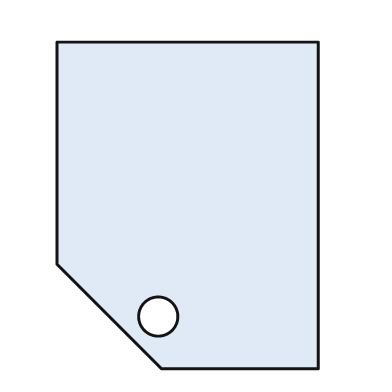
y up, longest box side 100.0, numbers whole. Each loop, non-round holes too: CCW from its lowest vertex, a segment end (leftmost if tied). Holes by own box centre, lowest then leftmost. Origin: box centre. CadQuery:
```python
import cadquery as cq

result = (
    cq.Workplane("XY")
    .moveTo(-8.0, -50.0)
    .lineTo(40.0, -50.0)
    .lineTo(40.0, 50.0)
    .lineTo(-40.0, 50.0)
    .lineTo(-40.0, -18.0)
    .close()
    .moveTo(-9.0, -34.0)
    .circle(6.0)
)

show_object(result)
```